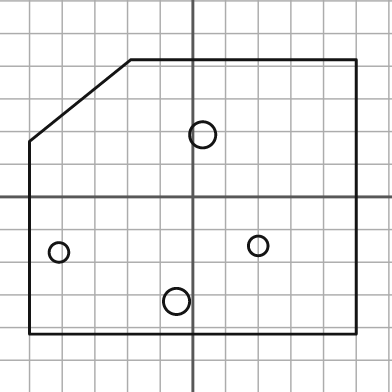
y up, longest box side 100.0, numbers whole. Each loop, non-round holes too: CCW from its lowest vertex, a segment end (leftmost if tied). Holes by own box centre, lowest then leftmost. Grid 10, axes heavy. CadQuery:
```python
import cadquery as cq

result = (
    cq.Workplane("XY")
    .moveTo(-50.0, -42.0)
    .lineTo(50.0, -42.0)
    .lineTo(50.0, 42.0)
    .lineTo(-19.0, 42.0)
    .lineTo(-50.0, 17.0)
    .close()
    .moveTo(-5.0, -32.0)
    .circle(4.0)
    .moveTo(-41.0, -17.0)
    .circle(3.0)
    .moveTo(20.0, -15.0)
    .circle(3.0)
    .moveTo(3.0, 19.0)
    .circle(4.0)
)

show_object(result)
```